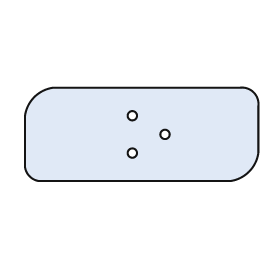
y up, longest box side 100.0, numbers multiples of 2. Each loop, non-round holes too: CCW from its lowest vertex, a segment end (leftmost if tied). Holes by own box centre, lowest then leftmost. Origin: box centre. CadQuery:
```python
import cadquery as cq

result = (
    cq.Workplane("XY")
    .moveTo(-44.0, -20.0)
    .lineTo(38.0, -20.0)
    .threePointArc((46.0, -16.0), (50.0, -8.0))
    .lineTo(50.0, 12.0)
    .threePointArc((48.0, 18.0), (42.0, 20.0))
    .lineTo(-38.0, 20.0)
    .threePointArc((-46.0, 16.0), (-50.0, 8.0))
    .lineTo(-50.0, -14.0)
    .threePointArc((-48.0, -18.0), (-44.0, -20.0))
    .close()
    .moveTo(-4.0, -8.0)
    .circle(2.0)
    .moveTo(10.0, 0.0)
    .circle(2.0)
    .moveTo(-4.0, 8.0)
    .circle(2.0)
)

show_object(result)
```